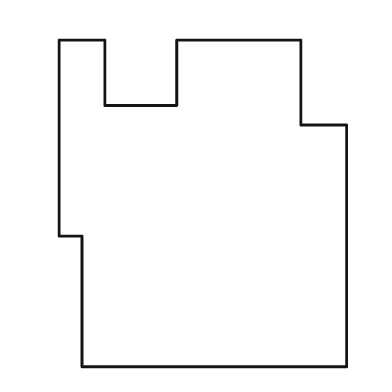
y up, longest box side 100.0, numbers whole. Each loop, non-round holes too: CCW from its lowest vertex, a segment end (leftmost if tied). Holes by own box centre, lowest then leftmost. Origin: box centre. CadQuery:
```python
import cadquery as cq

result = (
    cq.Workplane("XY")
    .moveTo(-37.0, -50.0)
    .lineTo(44.0, -50.0)
    .lineTo(44.0, 24.0)
    .lineTo(30.0, 24.0)
    .lineTo(30.0, 50.0)
    .lineTo(-8.0, 50.0)
    .lineTo(-8.0, 30.0)
    .lineTo(-30.0, 30.0)
    .lineTo(-30.0, 50.0)
    .lineTo(-44.0, 50.0)
    .lineTo(-44.0, -10.0)
    .lineTo(-37.0, -10.0)
    .close()
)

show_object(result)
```